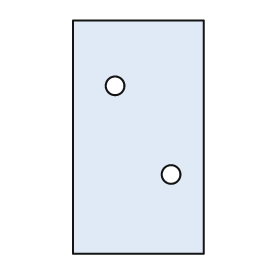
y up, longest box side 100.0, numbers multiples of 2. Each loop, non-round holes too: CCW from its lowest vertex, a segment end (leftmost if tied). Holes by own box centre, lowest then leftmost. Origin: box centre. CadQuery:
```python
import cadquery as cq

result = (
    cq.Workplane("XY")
    .moveTo(-28.0, -50.0)
    .lineTo(28.0, -50.0)
    .lineTo(28.0, 50.0)
    .lineTo(-28.0, 50.0)
    .close()
    .moveTo(14.0, -16.0)
    .circle(4.0)
    .moveTo(-10.0, 22.0)
    .circle(4.0)
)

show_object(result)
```